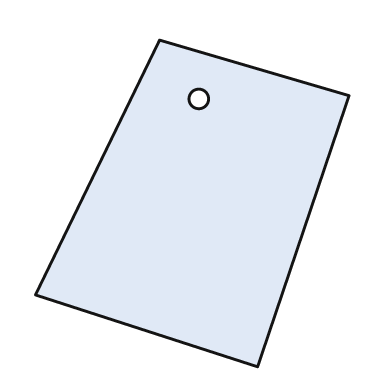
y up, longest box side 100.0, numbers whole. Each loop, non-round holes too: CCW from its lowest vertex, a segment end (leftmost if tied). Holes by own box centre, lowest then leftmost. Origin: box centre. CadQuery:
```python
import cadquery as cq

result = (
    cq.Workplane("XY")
    .moveTo(20.0, -50.0)
    .lineTo(48.0, 33.0)
    .lineTo(-10.0, 50.0)
    .lineTo(-48.0, -28.0)
    .close()
    .moveTo(2.0, 32.0)
    .circle(3.0)
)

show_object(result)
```